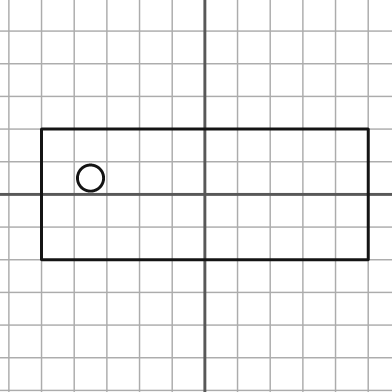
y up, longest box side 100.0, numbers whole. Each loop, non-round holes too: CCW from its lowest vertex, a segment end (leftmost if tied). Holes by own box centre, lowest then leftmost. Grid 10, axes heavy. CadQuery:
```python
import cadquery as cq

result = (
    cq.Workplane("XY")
    .moveTo(-50.0, -20.0)
    .lineTo(50.0, -20.0)
    .lineTo(50.0, 20.0)
    .lineTo(-50.0, 20.0)
    .close()
    .moveTo(-35.0, 5.0)
    .circle(4.0)
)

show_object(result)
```